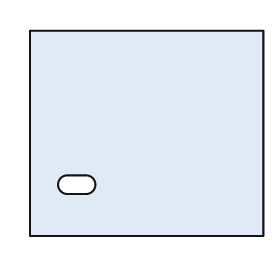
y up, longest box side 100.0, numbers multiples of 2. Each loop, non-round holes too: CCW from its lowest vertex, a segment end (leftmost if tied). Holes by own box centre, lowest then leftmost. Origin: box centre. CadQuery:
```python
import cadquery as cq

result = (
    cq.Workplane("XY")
    .moveTo(-50.0, -44.0)
    .lineTo(50.0, -44.0)
    .lineTo(50.0, 44.0)
    .lineTo(-50.0, 44.0)
    .close()
    .moveTo(-34.0, -26.0)
    .lineTo(-26.0, -26.0)
    .threePointArc((-22.0, -22.0), (-26.0, -18.0))
    .lineTo(-34.0, -18.0)
    .threePointArc((-38.0, -22.0), (-34.0, -26.0))
    .close()
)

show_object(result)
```